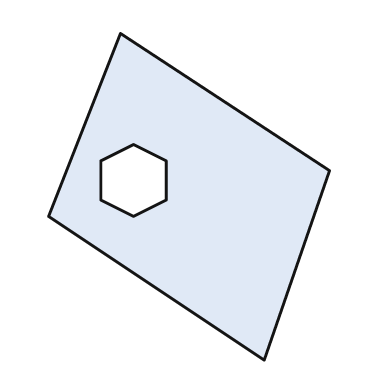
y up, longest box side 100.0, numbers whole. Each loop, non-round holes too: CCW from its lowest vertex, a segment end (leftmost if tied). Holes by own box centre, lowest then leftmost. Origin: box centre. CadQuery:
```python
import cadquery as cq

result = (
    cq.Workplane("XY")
    .moveTo(23.0, -50.0)
    .lineTo(43.0, 8.0)
    .lineTo(-21.0, 50.0)
    .lineTo(-43.0, -6.0)
    .close()
    .moveTo(-17.0, -6.0)
    .lineTo(-7.0, -1.0)
    .lineTo(-7.0, 11.0)
    .lineTo(-17.0, 16.0)
    .lineTo(-27.0, 11.0)
    .lineTo(-27.0, -1.0)
    .close()
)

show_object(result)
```